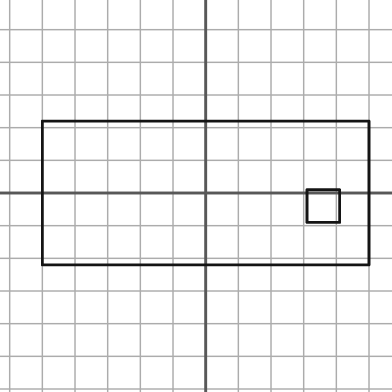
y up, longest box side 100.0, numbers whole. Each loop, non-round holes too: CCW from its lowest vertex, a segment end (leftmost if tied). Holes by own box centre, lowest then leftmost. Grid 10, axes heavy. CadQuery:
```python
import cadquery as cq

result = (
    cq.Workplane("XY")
    .moveTo(-50.0, -22.0)
    .lineTo(50.0, -22.0)
    .lineTo(50.0, 22.0)
    .lineTo(-50.0, 22.0)
    .close()
    .moveTo(31.0, -9.0)
    .lineTo(41.0, -9.0)
    .lineTo(41.0, 1.0)
    .lineTo(31.0, 1.0)
    .close()
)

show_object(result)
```